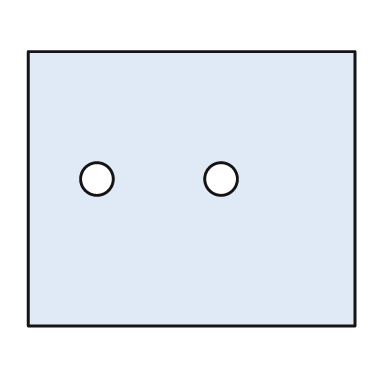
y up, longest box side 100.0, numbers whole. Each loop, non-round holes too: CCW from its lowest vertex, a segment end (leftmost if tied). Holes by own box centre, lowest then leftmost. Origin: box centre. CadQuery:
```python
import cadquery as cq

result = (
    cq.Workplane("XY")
    .moveTo(-50.0, -42.0)
    .lineTo(50.0, -42.0)
    .lineTo(50.0, 42.0)
    .lineTo(-50.0, 42.0)
    .close()
    .moveTo(-29.0, 3.0)
    .circle(5.0)
    .moveTo(9.0, 3.0)
    .circle(5.0)
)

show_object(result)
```